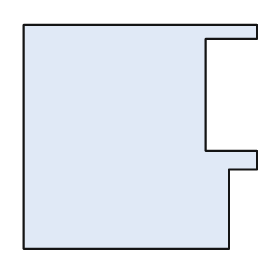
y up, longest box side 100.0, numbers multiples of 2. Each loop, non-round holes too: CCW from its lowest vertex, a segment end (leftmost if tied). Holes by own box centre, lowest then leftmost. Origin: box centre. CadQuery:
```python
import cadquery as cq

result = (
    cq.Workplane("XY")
    .moveTo(-50.0, -48.0)
    .lineTo(38.0, -48.0)
    .lineTo(38.0, -14.0)
    .lineTo(50.0, -14.0)
    .lineTo(50.0, -6.0)
    .lineTo(28.0, -6.0)
    .lineTo(28.0, 42.0)
    .lineTo(50.0, 42.0)
    .lineTo(50.0, 48.0)
    .lineTo(-50.0, 48.0)
    .close()
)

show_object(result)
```